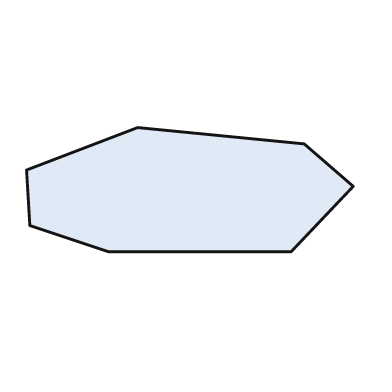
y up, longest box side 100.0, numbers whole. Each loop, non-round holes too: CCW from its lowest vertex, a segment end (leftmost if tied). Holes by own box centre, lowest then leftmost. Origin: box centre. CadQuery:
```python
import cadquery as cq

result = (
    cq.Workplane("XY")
    .moveTo(-25.0, -19.0)
    .lineTo(31.0, -19.0)
    .lineTo(50.0, 1.0)
    .lineTo(35.0, 14.0)
    .lineTo(-16.0, 19.0)
    .lineTo(-50.0, 6.0)
    .lineTo(-49.0, -11.0)
    .close()
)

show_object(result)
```